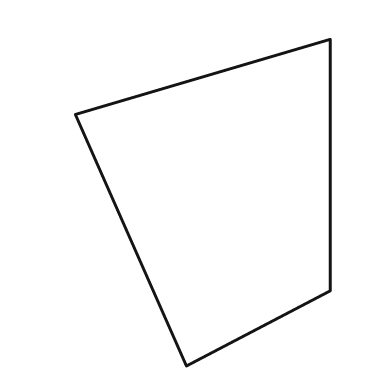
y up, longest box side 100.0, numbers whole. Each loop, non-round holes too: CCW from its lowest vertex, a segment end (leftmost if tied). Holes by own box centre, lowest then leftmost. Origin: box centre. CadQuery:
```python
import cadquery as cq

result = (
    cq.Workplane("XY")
    .moveTo(-5.0, -50.0)
    .lineTo(39.0, -27.0)
    .lineTo(39.0, 50.0)
    .lineTo(-39.0, 27.0)
    .close()
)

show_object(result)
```